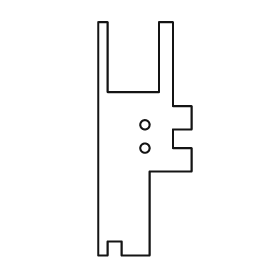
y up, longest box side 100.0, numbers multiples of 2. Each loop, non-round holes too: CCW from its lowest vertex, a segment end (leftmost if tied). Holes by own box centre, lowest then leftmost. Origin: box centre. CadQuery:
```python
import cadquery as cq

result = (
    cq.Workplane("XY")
    .moveTo(-20.0, -50.0)
    .lineTo(-16.0, -50.0)
    .lineTo(-16.0, -44.0)
    .lineTo(-10.0, -44.0)
    .lineTo(-10.0, -50.0)
    .lineTo(2.0, -50.0)
    .lineTo(2.0, -14.0)
    .lineTo(20.0, -14.0)
    .lineTo(20.0, -4.0)
    .lineTo(12.0, -4.0)
    .lineTo(12.0, 4.0)
    .lineTo(20.0, 4.0)
    .lineTo(20.0, 14.0)
    .lineTo(12.0, 14.0)
    .lineTo(12.0, 50.0)
    .lineTo(6.0, 50.0)
    .lineTo(6.0, 20.0)
    .lineTo(-16.0, 20.0)
    .lineTo(-16.0, 50.0)
    .lineTo(-20.0, 50.0)
    .close()
    .moveTo(0.0, -4.0)
    .circle(2.0)
    .moveTo(0.0, 6.0)
    .circle(2.0)
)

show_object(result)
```